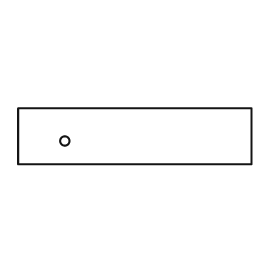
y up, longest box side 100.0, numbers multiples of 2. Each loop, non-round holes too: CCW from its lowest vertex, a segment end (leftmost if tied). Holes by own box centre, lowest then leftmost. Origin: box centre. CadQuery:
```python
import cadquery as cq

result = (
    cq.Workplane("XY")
    .moveTo(-50.0, -12.0)
    .lineTo(50.0, -12.0)
    .lineTo(50.0, 12.0)
    .lineTo(-50.0, 12.0)
    .close()
    .moveTo(-30.0, -2.0)
    .circle(2.0)
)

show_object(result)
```